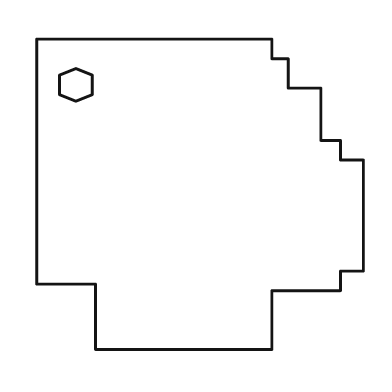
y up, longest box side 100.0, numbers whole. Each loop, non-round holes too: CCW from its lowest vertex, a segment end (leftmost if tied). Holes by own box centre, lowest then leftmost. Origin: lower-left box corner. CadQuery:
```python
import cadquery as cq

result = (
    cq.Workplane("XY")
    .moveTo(18.0, 0.0)
    .lineTo(72.0, 0.0)
    .lineTo(72.0, 18.0)
    .lineTo(93.0, 18.0)
    .lineTo(93.0, 24.0)
    .lineTo(100.0, 24.0)
    .lineTo(100.0, 58.0)
    .lineTo(93.0, 58.0)
    .lineTo(93.0, 64.0)
    .lineTo(87.0, 64.0)
    .lineTo(87.0, 80.0)
    .lineTo(77.0, 80.0)
    .lineTo(77.0, 89.0)
    .lineTo(72.0, 89.0)
    .lineTo(72.0, 95.0)
    .lineTo(0.0, 95.0)
    .lineTo(0.0, 20.0)
    .lineTo(18.0, 20.0)
    .close()
    .moveTo(12.0, 76.0)
    .lineTo(17.0, 78.0)
    .lineTo(17.0, 84.0)
    .lineTo(12.0, 86.0)
    .lineTo(7.0, 84.0)
    .lineTo(7.0, 78.0)
    .close()
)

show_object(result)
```